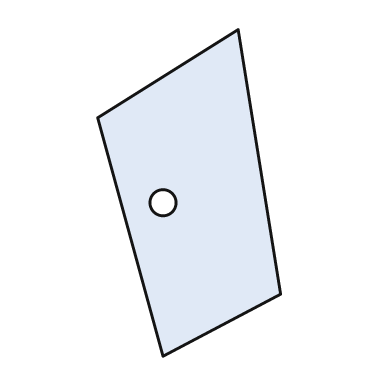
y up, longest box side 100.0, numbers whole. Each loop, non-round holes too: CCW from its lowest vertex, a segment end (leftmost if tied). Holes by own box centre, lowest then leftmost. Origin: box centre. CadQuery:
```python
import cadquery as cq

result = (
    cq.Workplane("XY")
    .moveTo(-8.0, -50.0)
    .lineTo(28.0, -31.0)
    .lineTo(15.0, 50.0)
    .lineTo(-28.0, 23.0)
    .close()
    .moveTo(-8.0, -3.0)
    .circle(4.0)
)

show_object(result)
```